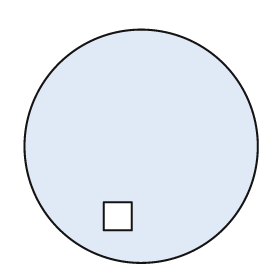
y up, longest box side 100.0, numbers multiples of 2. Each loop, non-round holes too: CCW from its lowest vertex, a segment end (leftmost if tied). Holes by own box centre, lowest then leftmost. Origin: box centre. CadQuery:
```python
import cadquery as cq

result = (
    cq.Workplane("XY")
    .moveTo(0.0, 0.0)
    .circle(50.0)
    .moveTo(-16.0, -36.0)
    .lineTo(-4.0, -36.0)
    .lineTo(-4.0, -24.0)
    .lineTo(-16.0, -24.0)
    .close()
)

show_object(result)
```